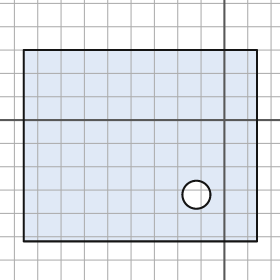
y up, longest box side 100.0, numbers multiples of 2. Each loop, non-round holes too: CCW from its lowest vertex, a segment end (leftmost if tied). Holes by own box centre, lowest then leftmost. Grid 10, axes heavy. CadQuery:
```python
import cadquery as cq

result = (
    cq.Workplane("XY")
    .moveTo(-86.0, -52.0)
    .lineTo(14.0, -52.0)
    .lineTo(14.0, 30.0)
    .lineTo(-86.0, 30.0)
    .close()
    .moveTo(-12.0, -32.0)
    .circle(6.0)
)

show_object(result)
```